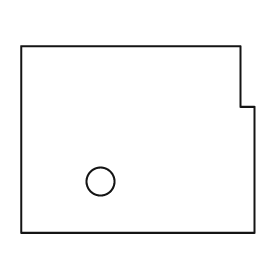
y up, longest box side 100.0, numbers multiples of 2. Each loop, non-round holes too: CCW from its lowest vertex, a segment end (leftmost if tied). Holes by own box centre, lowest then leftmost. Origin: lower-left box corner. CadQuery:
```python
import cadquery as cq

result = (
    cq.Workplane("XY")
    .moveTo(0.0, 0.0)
    .lineTo(100.0, 0.0)
    .lineTo(100.0, 54.0)
    .lineTo(94.0, 54.0)
    .lineTo(94.0, 80.0)
    .lineTo(0.0, 80.0)
    .close()
    .moveTo(34.0, 22.0)
    .circle(6.0)
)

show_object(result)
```